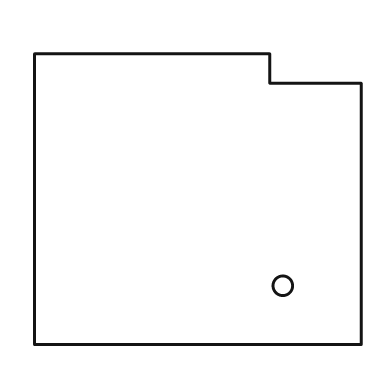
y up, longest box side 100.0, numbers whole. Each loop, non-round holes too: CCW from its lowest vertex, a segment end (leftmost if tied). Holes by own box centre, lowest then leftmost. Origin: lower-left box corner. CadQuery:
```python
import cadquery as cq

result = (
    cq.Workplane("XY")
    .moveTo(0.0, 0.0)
    .lineTo(100.0, 0.0)
    .lineTo(100.0, 80.0)
    .lineTo(72.0, 80.0)
    .lineTo(72.0, 89.0)
    .lineTo(0.0, 89.0)
    .close()
    .moveTo(76.0, 18.0)
    .circle(3.0)
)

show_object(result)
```